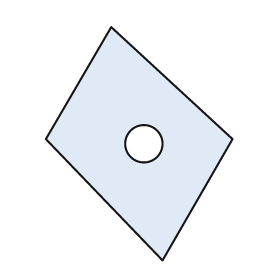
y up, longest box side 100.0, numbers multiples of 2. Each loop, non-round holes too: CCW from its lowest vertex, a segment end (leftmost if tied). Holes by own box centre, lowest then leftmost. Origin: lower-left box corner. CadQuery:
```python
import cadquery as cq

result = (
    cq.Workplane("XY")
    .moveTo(50.0, 0.0)
    .lineTo(80.0, 52.0)
    .lineTo(28.0, 100.0)
    .lineTo(0.0, 52.0)
    .close()
    .moveTo(42.0, 50.0)
    .circle(8.0)
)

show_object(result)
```